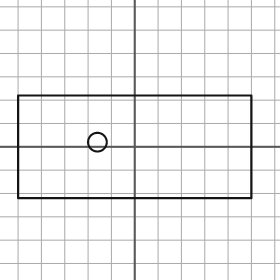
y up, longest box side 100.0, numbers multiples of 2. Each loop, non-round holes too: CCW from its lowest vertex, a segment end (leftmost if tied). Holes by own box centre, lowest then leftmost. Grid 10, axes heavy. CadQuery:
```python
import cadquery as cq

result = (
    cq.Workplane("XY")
    .moveTo(-50.0, -22.0)
    .lineTo(50.0, -22.0)
    .lineTo(50.0, 22.0)
    .lineTo(-50.0, 22.0)
    .close()
    .moveTo(-16.0, 2.0)
    .circle(4.0)
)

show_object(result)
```